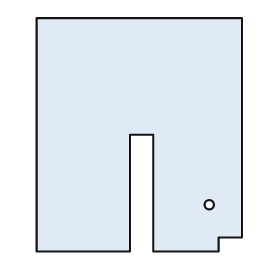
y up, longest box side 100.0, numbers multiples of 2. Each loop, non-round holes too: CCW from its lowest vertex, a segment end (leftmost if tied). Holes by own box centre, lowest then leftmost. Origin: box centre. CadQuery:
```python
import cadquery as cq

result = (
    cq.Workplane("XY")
    .moveTo(-44.0, -50.0)
    .lineTo(-4.0, -50.0)
    .lineTo(-4.0, 0.0)
    .lineTo(6.0, 0.0)
    .lineTo(6.0, -50.0)
    .lineTo(34.0, -50.0)
    .lineTo(34.0, -44.0)
    .lineTo(44.0, -44.0)
    .lineTo(44.0, 50.0)
    .lineTo(-44.0, 50.0)
    .close()
    .moveTo(30.0, -30.0)
    .circle(2.0)
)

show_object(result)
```